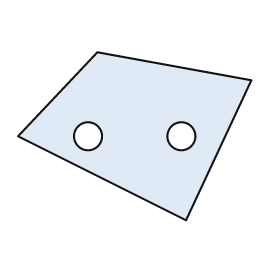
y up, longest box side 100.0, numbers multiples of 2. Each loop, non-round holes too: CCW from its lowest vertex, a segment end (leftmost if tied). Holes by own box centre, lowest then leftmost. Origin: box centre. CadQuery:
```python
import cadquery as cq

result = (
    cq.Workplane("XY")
    .moveTo(22.0, -36.0)
    .lineTo(50.0, 24.0)
    .lineTo(-16.0, 36.0)
    .lineTo(-50.0, 0.0)
    .close()
    .moveTo(-20.0, 0.0)
    .circle(6.0)
    .moveTo(20.0, 0.0)
    .circle(6.0)
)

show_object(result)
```